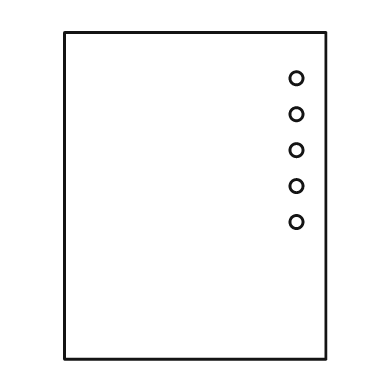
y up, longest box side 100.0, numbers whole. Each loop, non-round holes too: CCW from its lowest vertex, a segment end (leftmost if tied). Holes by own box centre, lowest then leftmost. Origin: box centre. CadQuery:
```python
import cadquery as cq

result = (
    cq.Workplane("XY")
    .moveTo(-40.0, -50.0)
    .lineTo(40.0, -50.0)
    .lineTo(40.0, 50.0)
    .lineTo(-40.0, 50.0)
    .close()
    .moveTo(31.0, -8.0)
    .circle(2.0)
    .moveTo(31.0, 3.0)
    .circle(2.0)
    .moveTo(31.0, 14.0)
    .circle(2.0)
    .moveTo(31.0, 25.0)
    .circle(2.0)
    .moveTo(31.0, 36.0)
    .circle(2.0)
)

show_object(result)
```